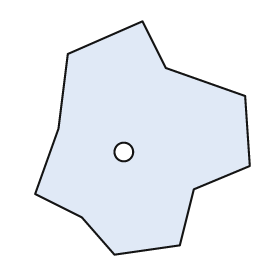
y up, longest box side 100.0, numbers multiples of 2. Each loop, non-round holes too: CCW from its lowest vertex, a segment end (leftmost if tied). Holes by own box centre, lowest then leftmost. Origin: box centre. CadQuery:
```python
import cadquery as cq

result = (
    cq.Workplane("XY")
    .moveTo(-12.0, -50.0)
    .lineTo(16.0, -46.0)
    .lineTo(22.0, -22.0)
    .lineTo(46.0, -12.0)
    .lineTo(44.0, 18.0)
    .lineTo(10.0, 30.0)
    .lineTo(0.0, 50.0)
    .lineTo(-32.0, 36.0)
    .lineTo(-36.0, 4.0)
    .lineTo(-46.0, -24.0)
    .lineTo(-26.0, -34.0)
    .close()
    .moveTo(-8.0, -6.0)
    .circle(4.0)
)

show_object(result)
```